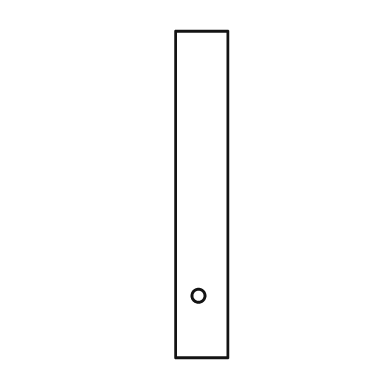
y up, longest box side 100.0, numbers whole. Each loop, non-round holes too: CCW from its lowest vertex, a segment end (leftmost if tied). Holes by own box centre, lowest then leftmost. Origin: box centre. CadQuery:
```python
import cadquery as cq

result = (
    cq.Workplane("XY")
    .moveTo(-8.0, -50.0)
    .lineTo(8.0, -50.0)
    .lineTo(8.0, 50.0)
    .lineTo(-8.0, 50.0)
    .close()
    .moveTo(-1.0, -31.0)
    .circle(2.0)
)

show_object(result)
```